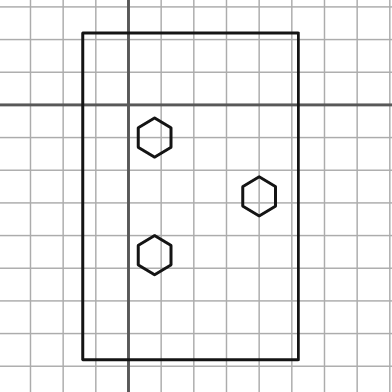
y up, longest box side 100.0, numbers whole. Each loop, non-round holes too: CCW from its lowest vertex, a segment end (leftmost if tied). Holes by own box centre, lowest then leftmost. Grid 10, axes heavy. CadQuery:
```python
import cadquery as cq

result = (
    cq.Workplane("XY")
    .moveTo(-14.0, -78.0)
    .lineTo(52.0, -78.0)
    .lineTo(52.0, 22.0)
    .lineTo(-14.0, 22.0)
    .close()
    .moveTo(8.0, -52.0)
    .lineTo(13.0, -49.0)
    .lineTo(13.0, -43.0)
    .lineTo(8.0, -40.0)
    .lineTo(3.0, -43.0)
    .lineTo(3.0, -49.0)
    .close()
    .moveTo(40.0, -34.0)
    .lineTo(45.0, -31.0)
    .lineTo(45.0, -25.0)
    .lineTo(40.0, -22.0)
    .lineTo(35.0, -25.0)
    .lineTo(35.0, -31.0)
    .close()
    .moveTo(8.0, -16.0)
    .lineTo(13.0, -13.0)
    .lineTo(13.0, -7.0)
    .lineTo(8.0, -4.0)
    .lineTo(3.0, -7.0)
    .lineTo(3.0, -13.0)
    .close()
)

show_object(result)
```